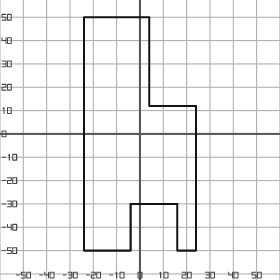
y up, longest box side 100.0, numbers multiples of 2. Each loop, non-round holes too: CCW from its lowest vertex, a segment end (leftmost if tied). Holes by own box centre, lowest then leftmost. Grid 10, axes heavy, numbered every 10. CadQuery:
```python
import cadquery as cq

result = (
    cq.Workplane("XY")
    .moveTo(-24.0, -50.0)
    .lineTo(-4.0, -50.0)
    .lineTo(-4.0, -30.0)
    .lineTo(16.0, -30.0)
    .lineTo(16.0, -50.0)
    .lineTo(24.0, -50.0)
    .lineTo(24.0, 12.0)
    .lineTo(4.0, 12.0)
    .lineTo(4.0, 50.0)
    .lineTo(-24.0, 50.0)
    .close()
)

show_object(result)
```